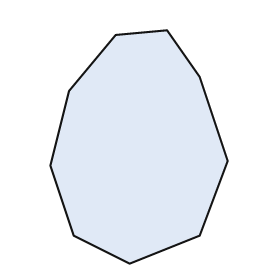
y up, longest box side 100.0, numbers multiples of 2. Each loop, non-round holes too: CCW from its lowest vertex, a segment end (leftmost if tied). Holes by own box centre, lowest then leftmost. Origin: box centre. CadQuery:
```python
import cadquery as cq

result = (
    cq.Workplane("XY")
    .moveTo(-4.0, -50.0)
    .lineTo(26.0, -38.0)
    .lineTo(38.0, -6.0)
    .lineTo(26.0, 30.0)
    .lineTo(12.0, 50.0)
    .lineTo(-10.0, 48.0)
    .lineTo(-30.0, 24.0)
    .lineTo(-38.0, -8.0)
    .lineTo(-28.0, -38.0)
    .close()
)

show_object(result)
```